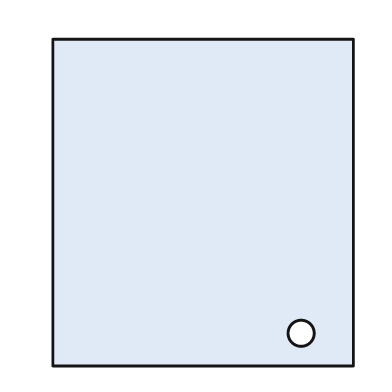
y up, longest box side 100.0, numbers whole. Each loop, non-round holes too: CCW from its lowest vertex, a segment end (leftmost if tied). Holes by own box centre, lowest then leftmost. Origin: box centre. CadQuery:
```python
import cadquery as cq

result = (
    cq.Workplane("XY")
    .moveTo(-46.0, -50.0)
    .lineTo(46.0, -50.0)
    .lineTo(46.0, 50.0)
    .lineTo(-46.0, 50.0)
    .close()
    .moveTo(30.0, -40.0)
    .circle(4.0)
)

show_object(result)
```